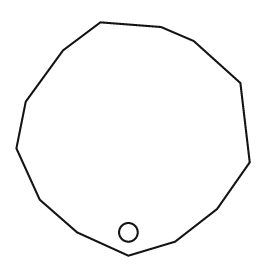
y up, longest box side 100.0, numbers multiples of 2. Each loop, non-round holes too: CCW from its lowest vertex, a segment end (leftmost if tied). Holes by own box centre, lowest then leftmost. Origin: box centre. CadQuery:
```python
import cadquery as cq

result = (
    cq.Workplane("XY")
    .moveTo(-2.0, -50.0)
    .lineTo(18.0, -44.0)
    .lineTo(36.0, -30.0)
    .lineTo(50.0, -10.0)
    .lineTo(46.0, 24.0)
    .lineTo(26.0, 42.0)
    .lineTo(12.0, 48.0)
    .lineTo(-14.0, 50.0)
    .lineTo(-30.0, 38.0)
    .lineTo(-46.0, 16.0)
    .lineTo(-50.0, -4.0)
    .lineTo(-40.0, -26.0)
    .lineTo(-24.0, -40.0)
    .close()
    .moveTo(-2.0, -40.0)
    .circle(4.0)
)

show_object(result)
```